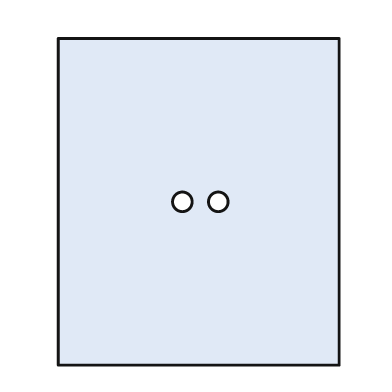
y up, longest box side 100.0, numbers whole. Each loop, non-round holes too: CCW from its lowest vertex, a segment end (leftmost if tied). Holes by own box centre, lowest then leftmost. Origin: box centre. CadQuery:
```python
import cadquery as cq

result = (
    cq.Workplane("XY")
    .moveTo(-43.0, -50.0)
    .lineTo(43.0, -50.0)
    .lineTo(43.0, 50.0)
    .lineTo(-43.0, 50.0)
    .close()
    .moveTo(-5.0, 0.0)
    .circle(3.0)
    .moveTo(6.0, 0.0)
    .circle(3.0)
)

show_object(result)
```